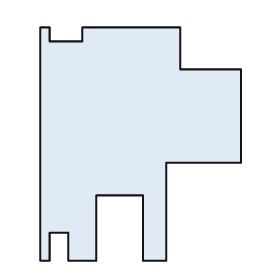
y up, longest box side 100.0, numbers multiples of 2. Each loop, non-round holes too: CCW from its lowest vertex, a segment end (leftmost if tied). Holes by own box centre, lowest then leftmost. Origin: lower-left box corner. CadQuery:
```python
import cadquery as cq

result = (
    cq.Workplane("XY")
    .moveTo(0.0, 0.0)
    .lineTo(4.0, 0.0)
    .lineTo(4.0, 12.0)
    .lineTo(12.0, 12.0)
    .lineTo(12.0, 0.0)
    .lineTo(24.0, 0.0)
    .lineTo(24.0, 28.0)
    .lineTo(44.0, 28.0)
    .lineTo(44.0, 0.0)
    .lineTo(54.0, 0.0)
    .lineTo(54.0, 42.0)
    .lineTo(86.0, 42.0)
    .lineTo(86.0, 82.0)
    .lineTo(60.0, 82.0)
    .lineTo(60.0, 100.0)
    .lineTo(18.0, 100.0)
    .lineTo(18.0, 94.0)
    .lineTo(4.0, 94.0)
    .lineTo(4.0, 100.0)
    .lineTo(0.0, 100.0)
    .close()
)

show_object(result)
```